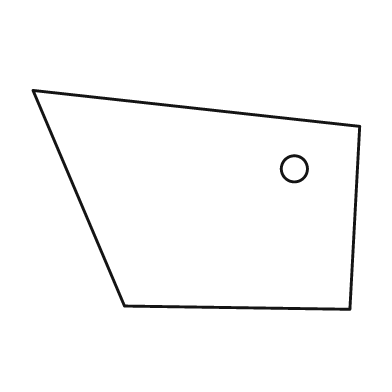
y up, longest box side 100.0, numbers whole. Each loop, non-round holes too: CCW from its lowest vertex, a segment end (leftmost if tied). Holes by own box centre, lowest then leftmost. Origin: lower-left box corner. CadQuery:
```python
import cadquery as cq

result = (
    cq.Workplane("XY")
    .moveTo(97.0, 0.0)
    .lineTo(100.0, 56.0)
    .lineTo(0.0, 67.0)
    .lineTo(28.0, 1.0)
    .close()
    .moveTo(80.0, 43.0)
    .circle(4.0)
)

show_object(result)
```